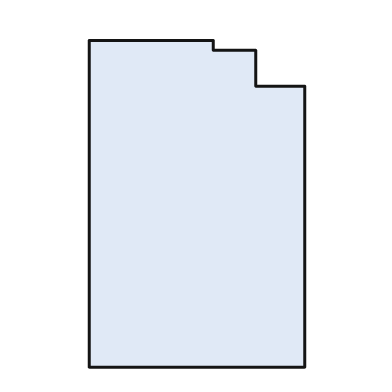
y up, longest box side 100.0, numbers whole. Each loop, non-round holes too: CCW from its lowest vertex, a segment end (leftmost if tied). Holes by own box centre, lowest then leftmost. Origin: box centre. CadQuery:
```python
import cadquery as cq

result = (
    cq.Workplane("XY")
    .moveTo(-33.0, -50.0)
    .lineTo(33.0, -50.0)
    .lineTo(33.0, 36.0)
    .lineTo(18.0, 36.0)
    .lineTo(18.0, 47.0)
    .lineTo(5.0, 47.0)
    .lineTo(5.0, 50.0)
    .lineTo(-33.0, 50.0)
    .close()
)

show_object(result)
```